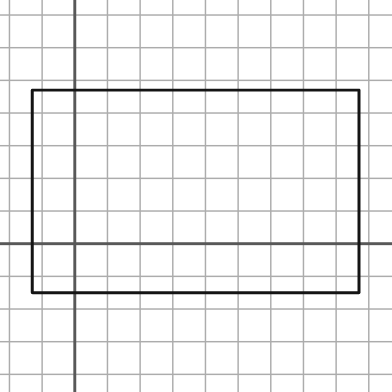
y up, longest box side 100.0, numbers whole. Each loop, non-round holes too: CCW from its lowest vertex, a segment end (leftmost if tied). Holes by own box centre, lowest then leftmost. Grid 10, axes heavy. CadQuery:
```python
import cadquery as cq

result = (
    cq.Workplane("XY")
    .moveTo(-13.0, -15.0)
    .lineTo(87.0, -15.0)
    .lineTo(87.0, 47.0)
    .lineTo(-13.0, 47.0)
    .close()
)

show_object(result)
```